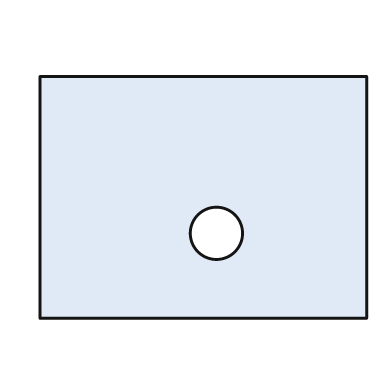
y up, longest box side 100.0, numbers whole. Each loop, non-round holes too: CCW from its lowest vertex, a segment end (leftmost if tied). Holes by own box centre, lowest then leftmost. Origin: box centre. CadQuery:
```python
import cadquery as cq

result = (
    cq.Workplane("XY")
    .moveTo(-50.0, -37.0)
    .lineTo(50.0, -37.0)
    .lineTo(50.0, 37.0)
    .lineTo(-50.0, 37.0)
    .close()
    .moveTo(4.0, -11.0)
    .circle(8.0)
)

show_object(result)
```